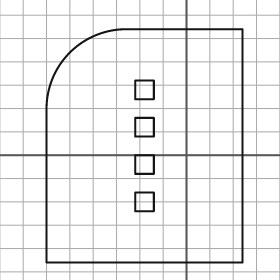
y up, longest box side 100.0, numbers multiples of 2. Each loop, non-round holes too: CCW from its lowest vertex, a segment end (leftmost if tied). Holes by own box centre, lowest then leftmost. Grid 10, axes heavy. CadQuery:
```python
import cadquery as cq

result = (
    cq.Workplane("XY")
    .moveTo(-60.0, -46.0)
    .lineTo(24.0, -46.0)
    .lineTo(24.0, 54.0)
    .lineTo(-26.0, 54.0)
    .threePointArc((-50.0, 44.0), (-60.0, 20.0))
    .close()
    .moveTo(-22.0, -24.0)
    .lineTo(-14.0, -24.0)
    .lineTo(-14.0, -16.0)
    .lineTo(-22.0, -16.0)
    .close()
    .moveTo(-22.0, -8.0)
    .lineTo(-14.0, -8.0)
    .lineTo(-14.0, 0.0)
    .lineTo(-22.0, 0.0)
    .close()
    .moveTo(-22.0, 8.0)
    .lineTo(-14.0, 8.0)
    .lineTo(-14.0, 16.0)
    .lineTo(-22.0, 16.0)
    .close()
    .moveTo(-22.0, 24.0)
    .lineTo(-14.0, 24.0)
    .lineTo(-14.0, 32.0)
    .lineTo(-22.0, 32.0)
    .close()
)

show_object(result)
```